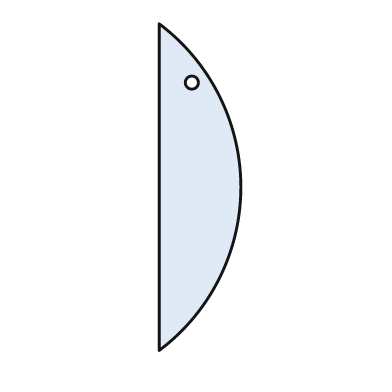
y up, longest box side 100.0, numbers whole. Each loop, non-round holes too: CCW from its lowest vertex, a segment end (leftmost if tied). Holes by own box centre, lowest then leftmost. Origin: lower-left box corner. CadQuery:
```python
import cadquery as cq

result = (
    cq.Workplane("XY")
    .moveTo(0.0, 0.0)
    .threePointArc((25.0, 50.0), (0.0, 100.0))
    .close()
    .moveTo(10.0, 82.0)
    .circle(2.0)
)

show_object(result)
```